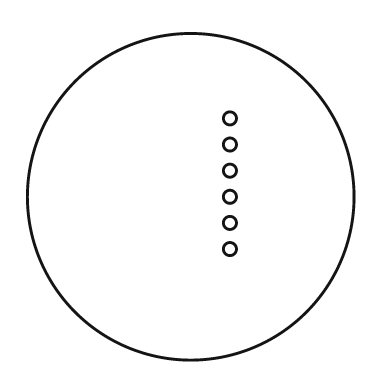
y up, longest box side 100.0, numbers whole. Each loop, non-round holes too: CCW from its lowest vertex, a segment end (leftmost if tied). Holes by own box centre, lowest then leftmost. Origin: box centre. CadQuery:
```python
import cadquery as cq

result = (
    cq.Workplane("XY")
    .moveTo(0.0, 0.0)
    .circle(50.0)
    .moveTo(12.0, -16.0)
    .circle(2.0)
    .moveTo(12.0, -8.0)
    .circle(2.0)
    .moveTo(12.0, 0.0)
    .circle(2.0)
    .moveTo(12.0, 8.0)
    .circle(2.0)
    .moveTo(12.0, 16.0)
    .circle(2.0)
    .moveTo(12.0, 24.0)
    .circle(2.0)
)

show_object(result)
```